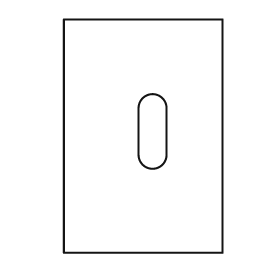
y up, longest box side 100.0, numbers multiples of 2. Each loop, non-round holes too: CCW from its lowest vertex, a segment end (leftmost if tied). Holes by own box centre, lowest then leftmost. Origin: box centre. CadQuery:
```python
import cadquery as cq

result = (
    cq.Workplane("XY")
    .moveTo(-34.0, -50.0)
    .lineTo(34.0, -50.0)
    .lineTo(34.0, 50.0)
    .lineTo(-34.0, 50.0)
    .close()
    .moveTo(-2.0, -8.0)
    .threePointArc((4.0, -14.0), (10.0, -8.0))
    .lineTo(10.0, 12.0)
    .threePointArc((4.0, 18.0), (-2.0, 12.0))
    .close()
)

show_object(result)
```